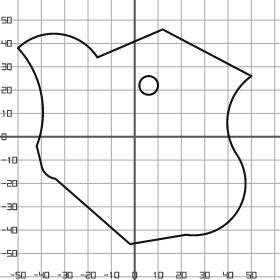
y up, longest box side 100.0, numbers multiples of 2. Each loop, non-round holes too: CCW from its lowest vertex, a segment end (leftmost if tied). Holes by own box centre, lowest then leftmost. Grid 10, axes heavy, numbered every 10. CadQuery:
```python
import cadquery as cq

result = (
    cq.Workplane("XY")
    .moveTo(-2.0, -46.0)
    .lineTo(22.0, -42.0)
    .threePointArc((44.0, -32.0), (44.0, -8.0))
    .threePointArc((40.0, 10.0), (50.0, 26.0))
    .lineTo(12.0, 46.0)
    .lineTo(-16.0, 34.0)
    .threePointArc((-32.0, 44.0), (-50.0, 38.0))
    .threePointArc((-40.0, 18.0), (-42.0, -4.0))
    .lineTo(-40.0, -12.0)
    .threePointArc((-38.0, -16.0), (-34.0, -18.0))
    .close()
    .moveTo(6.0, 22.0)
    .circle(4.0)
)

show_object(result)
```